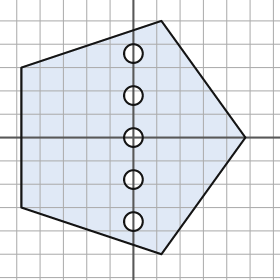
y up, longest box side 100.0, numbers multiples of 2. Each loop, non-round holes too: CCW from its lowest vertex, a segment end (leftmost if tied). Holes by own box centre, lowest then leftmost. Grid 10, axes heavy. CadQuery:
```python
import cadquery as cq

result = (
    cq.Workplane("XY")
    .moveTo(12.0, -50.0)
    .lineTo(48.0, 0.0)
    .lineTo(12.0, 50.0)
    .lineTo(-48.0, 30.0)
    .lineTo(-48.0, -30.0)
    .close()
    .moveTo(0.0, -36.0)
    .circle(4.0)
    .moveTo(0.0, -18.0)
    .circle(4.0)
    .moveTo(0.0, 0.0)
    .circle(4.0)
    .moveTo(0.0, 18.0)
    .circle(4.0)
    .moveTo(0.0, 36.0)
    .circle(4.0)
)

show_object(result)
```